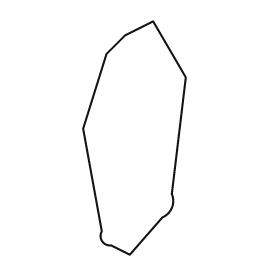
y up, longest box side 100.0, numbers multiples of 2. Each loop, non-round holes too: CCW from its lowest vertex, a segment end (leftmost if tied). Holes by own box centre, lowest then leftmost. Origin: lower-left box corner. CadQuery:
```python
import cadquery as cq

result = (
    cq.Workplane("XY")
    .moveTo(20.0, 0.0)
    .lineTo(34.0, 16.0)
    .threePointArc((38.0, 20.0), (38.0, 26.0))
    .lineTo(44.0, 76.0)
    .lineTo(30.0, 100.0)
    .lineTo(18.0, 94.0)
    .lineTo(10.0, 86.0)
    .lineTo(0.0, 54.0)
    .lineTo(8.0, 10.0)
    .threePointArc((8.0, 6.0), (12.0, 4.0))
    .close()
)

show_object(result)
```